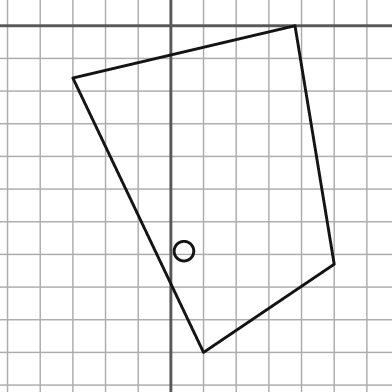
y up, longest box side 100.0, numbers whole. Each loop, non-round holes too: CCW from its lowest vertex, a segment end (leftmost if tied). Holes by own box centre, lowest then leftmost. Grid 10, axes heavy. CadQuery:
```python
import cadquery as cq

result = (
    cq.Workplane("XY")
    .moveTo(10.0, -100.0)
    .lineTo(50.0, -73.0)
    .lineTo(38.0, 0.0)
    .lineTo(-30.0, -16.0)
    .close()
    .moveTo(4.0, -69.0)
    .circle(3.0)
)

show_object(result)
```